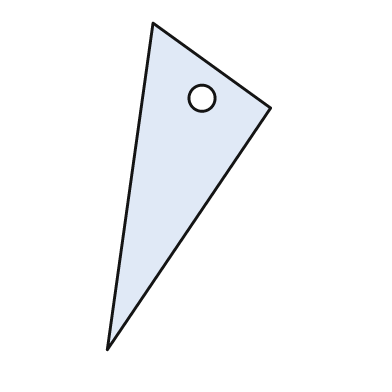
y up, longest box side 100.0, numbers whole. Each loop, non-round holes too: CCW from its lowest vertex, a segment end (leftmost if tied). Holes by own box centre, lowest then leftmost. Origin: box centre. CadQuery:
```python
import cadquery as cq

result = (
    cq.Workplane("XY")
    .moveTo(-25.0, -50.0)
    .lineTo(25.0, 24.0)
    .lineTo(-11.0, 50.0)
    .close()
    .moveTo(4.0, 27.0)
    .circle(4.0)
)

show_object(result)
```